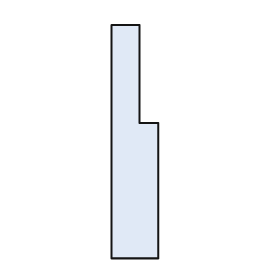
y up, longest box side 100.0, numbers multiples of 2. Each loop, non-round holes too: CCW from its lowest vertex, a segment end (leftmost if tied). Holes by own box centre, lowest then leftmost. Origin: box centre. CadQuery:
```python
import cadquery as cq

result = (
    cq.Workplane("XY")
    .moveTo(-10.0, -50.0)
    .lineTo(10.0, -50.0)
    .lineTo(10.0, 8.0)
    .lineTo(2.0, 8.0)
    .lineTo(2.0, 50.0)
    .lineTo(-10.0, 50.0)
    .close()
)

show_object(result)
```